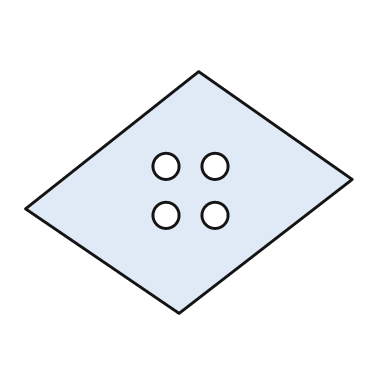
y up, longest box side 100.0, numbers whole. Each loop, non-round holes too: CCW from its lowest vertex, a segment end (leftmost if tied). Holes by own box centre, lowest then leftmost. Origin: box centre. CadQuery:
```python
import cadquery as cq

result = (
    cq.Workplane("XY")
    .moveTo(-3.0, -37.0)
    .lineTo(50.0, 4.0)
    .lineTo(3.0, 37.0)
    .lineTo(-50.0, -5.0)
    .close()
    .moveTo(-7.0, -7.0)
    .circle(4.0)
    .moveTo(8.0, -7.0)
    .circle(4.0)
    .moveTo(-7.0, 8.0)
    .circle(4.0)
    .moveTo(8.0, 8.0)
    .circle(4.0)
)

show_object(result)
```